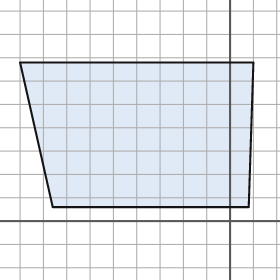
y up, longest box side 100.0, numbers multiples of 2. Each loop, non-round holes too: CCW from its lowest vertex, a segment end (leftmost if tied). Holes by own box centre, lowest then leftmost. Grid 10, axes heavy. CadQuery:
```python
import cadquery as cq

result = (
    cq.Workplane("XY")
    .moveTo(-76.0, 6.0)
    .lineTo(8.0, 6.0)
    .lineTo(10.0, 68.0)
    .lineTo(-90.0, 68.0)
    .close()
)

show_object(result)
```